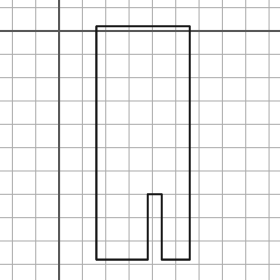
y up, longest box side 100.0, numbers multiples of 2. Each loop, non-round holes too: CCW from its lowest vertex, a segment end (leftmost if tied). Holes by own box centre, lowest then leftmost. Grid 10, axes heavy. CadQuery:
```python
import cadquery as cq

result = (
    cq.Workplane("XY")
    .moveTo(16.0, -98.0)
    .lineTo(38.0, -98.0)
    .lineTo(38.0, -70.0)
    .lineTo(44.0, -70.0)
    .lineTo(44.0, -98.0)
    .lineTo(56.0, -98.0)
    .lineTo(56.0, 2.0)
    .lineTo(16.0, 2.0)
    .close()
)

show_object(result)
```